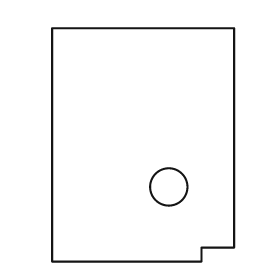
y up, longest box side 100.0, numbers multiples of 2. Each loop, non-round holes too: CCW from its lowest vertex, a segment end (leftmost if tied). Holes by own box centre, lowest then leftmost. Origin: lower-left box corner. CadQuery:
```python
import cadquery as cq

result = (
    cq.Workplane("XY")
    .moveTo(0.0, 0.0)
    .lineTo(64.0, 0.0)
    .lineTo(64.0, 6.0)
    .lineTo(78.0, 6.0)
    .lineTo(78.0, 100.0)
    .lineTo(0.0, 100.0)
    .close()
    .moveTo(50.0, 32.0)
    .circle(8.0)
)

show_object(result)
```